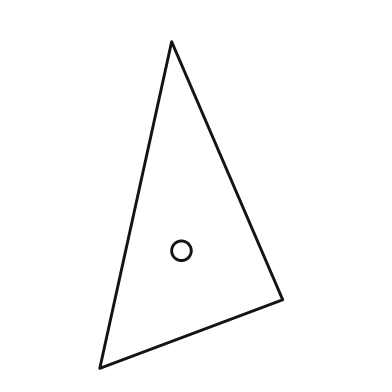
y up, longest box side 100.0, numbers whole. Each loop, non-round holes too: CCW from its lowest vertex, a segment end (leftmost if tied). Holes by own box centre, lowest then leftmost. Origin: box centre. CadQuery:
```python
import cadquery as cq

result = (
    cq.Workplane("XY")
    .moveTo(-28.0, -50.0)
    .lineTo(28.0, -29.0)
    .lineTo(-6.0, 50.0)
    .close()
    .moveTo(-3.0, -14.0)
    .circle(3.0)
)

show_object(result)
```